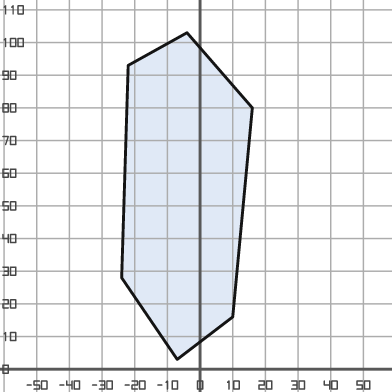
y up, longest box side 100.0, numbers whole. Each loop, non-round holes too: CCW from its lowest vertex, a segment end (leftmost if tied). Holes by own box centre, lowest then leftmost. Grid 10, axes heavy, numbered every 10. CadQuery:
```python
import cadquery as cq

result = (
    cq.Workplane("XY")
    .moveTo(-7.0, 3.0)
    .lineTo(10.0, 16.0)
    .lineTo(16.0, 80.0)
    .lineTo(-4.0, 103.0)
    .lineTo(-22.0, 93.0)
    .lineTo(-24.0, 28.0)
    .close()
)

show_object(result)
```